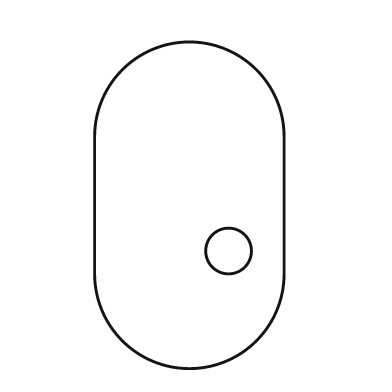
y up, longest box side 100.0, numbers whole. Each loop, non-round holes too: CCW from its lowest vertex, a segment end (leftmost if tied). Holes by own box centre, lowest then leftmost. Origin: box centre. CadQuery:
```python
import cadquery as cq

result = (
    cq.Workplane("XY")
    .moveTo(-29.0, -21.0)
    .threePointArc((0.0, -50.0), (29.0, -21.0))
    .lineTo(29.0, 21.0)
    .threePointArc((0.0, 50.0), (-29.0, 21.0))
    .close()
    .moveTo(12.0, -14.0)
    .circle(7.0)
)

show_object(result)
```